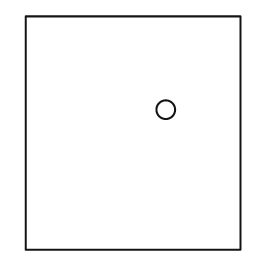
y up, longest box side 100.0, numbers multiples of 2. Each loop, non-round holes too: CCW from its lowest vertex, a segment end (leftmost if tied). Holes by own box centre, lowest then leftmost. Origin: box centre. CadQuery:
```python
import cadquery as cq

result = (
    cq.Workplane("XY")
    .moveTo(-46.0, -50.0)
    .lineTo(46.0, -50.0)
    .lineTo(46.0, 50.0)
    .lineTo(-46.0, 50.0)
    .close()
    .moveTo(14.0, 10.0)
    .circle(4.0)
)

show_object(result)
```